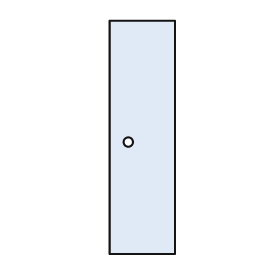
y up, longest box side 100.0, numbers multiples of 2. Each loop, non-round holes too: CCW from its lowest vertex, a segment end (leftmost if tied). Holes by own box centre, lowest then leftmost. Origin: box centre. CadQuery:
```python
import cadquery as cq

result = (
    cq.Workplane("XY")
    .moveTo(-14.0, -50.0)
    .lineTo(14.0, -50.0)
    .lineTo(14.0, 50.0)
    .lineTo(-14.0, 50.0)
    .close()
    .moveTo(-6.0, -2.0)
    .circle(2.0)
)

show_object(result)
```